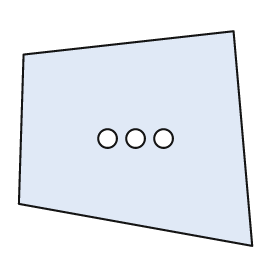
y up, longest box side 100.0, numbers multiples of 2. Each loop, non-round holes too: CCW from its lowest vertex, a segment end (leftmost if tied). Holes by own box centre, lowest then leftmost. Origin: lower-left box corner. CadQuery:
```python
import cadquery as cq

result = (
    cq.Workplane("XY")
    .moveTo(100.0, 0.0)
    .lineTo(92.0, 92.0)
    .lineTo(2.0, 82.0)
    .lineTo(0.0, 18.0)
    .close()
    .moveTo(38.0, 46.0)
    .circle(4.0)
    .moveTo(50.0, 46.0)
    .circle(4.0)
    .moveTo(62.0, 46.0)
    .circle(4.0)
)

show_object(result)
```